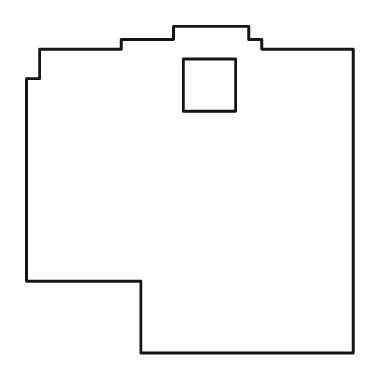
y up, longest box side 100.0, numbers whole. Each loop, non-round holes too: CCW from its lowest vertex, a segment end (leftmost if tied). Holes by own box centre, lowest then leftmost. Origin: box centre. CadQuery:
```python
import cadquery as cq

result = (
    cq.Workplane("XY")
    .moveTo(-15.0, -50.0)
    .lineTo(50.0, -50.0)
    .lineTo(50.0, 43.0)
    .lineTo(22.0, 43.0)
    .lineTo(22.0, 46.0)
    .lineTo(18.0, 46.0)
    .lineTo(18.0, 50.0)
    .lineTo(-5.0, 50.0)
    .lineTo(-5.0, 46.0)
    .lineTo(-21.0, 46.0)
    .lineTo(-21.0, 43.0)
    .lineTo(-46.0, 43.0)
    .lineTo(-46.0, 34.0)
    .lineTo(-50.0, 34.0)
    .lineTo(-50.0, -28.0)
    .lineTo(-15.0, -28.0)
    .close()
    .moveTo(-2.0, 24.0)
    .lineTo(14.0, 24.0)
    .lineTo(14.0, 40.0)
    .lineTo(-2.0, 40.0)
    .close()
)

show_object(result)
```